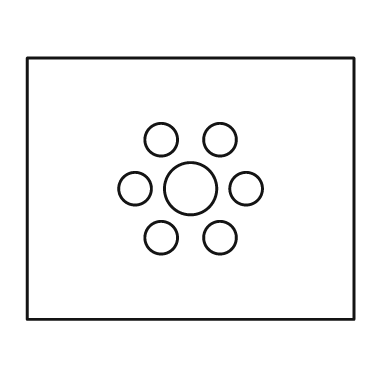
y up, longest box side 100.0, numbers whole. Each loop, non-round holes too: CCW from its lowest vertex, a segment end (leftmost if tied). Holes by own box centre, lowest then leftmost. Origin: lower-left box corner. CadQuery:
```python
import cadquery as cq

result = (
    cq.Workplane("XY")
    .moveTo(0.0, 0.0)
    .lineTo(100.0, 0.0)
    .lineTo(100.0, 80.0)
    .lineTo(0.0, 80.0)
    .close()
    .moveTo(41.0, 25.0)
    .circle(5.0)
    .moveTo(59.0, 25.0)
    .circle(5.0)
    .moveTo(33.0, 40.0)
    .circle(5.0)
    .moveTo(50.0, 40.0)
    .circle(8.0)
    .moveTo(67.0, 40.0)
    .circle(5.0)
    .moveTo(41.0, 55.0)
    .circle(5.0)
    .moveTo(59.0, 55.0)
    .circle(5.0)
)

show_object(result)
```